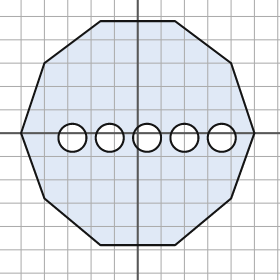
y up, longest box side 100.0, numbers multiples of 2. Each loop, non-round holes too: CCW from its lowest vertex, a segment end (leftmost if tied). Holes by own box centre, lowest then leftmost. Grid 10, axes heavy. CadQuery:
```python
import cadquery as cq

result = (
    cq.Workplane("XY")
    .moveTo(-16.0, -48.0)
    .lineTo(16.0, -48.0)
    .lineTo(40.0, -28.0)
    .lineTo(50.0, 0.0)
    .lineTo(40.0, 30.0)
    .lineTo(16.0, 48.0)
    .lineTo(-16.0, 48.0)
    .lineTo(-40.0, 30.0)
    .lineTo(-50.0, 0.0)
    .lineTo(-40.0, -28.0)
    .close()
    .moveTo(-28.0, -2.0)
    .circle(6.0)
    .moveTo(-12.0, -2.0)
    .circle(6.0)
    .moveTo(4.0, -2.0)
    .circle(6.0)
    .moveTo(20.0, -2.0)
    .circle(6.0)
    .moveTo(36.0, -2.0)
    .circle(6.0)
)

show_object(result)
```